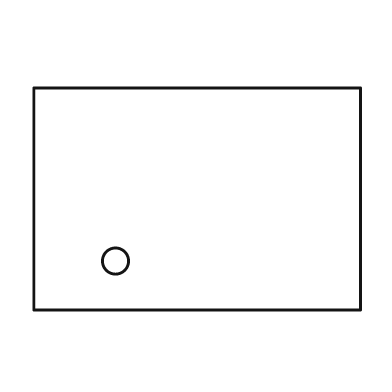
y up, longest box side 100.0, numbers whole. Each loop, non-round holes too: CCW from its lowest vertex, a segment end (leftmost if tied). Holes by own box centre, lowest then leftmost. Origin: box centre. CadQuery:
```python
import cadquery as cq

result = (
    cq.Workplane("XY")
    .moveTo(-50.0, -34.0)
    .lineTo(50.0, -34.0)
    .lineTo(50.0, 34.0)
    .lineTo(-50.0, 34.0)
    .close()
    .moveTo(-25.0, -19.0)
    .circle(4.0)
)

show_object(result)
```